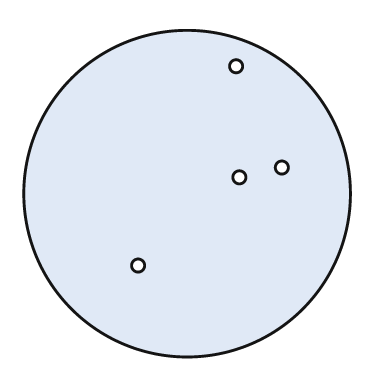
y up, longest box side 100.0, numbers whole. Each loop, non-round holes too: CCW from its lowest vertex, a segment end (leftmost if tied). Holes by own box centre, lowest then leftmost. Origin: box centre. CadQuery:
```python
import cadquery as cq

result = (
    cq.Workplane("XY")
    .moveTo(0.0, 0.0)
    .circle(50.0)
    .moveTo(-15.0, -22.0)
    .circle(2.0)
    .moveTo(16.0, 5.0)
    .circle(2.0)
    .moveTo(29.0, 8.0)
    .circle(2.0)
    .moveTo(15.0, 39.0)
    .circle(2.0)
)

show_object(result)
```